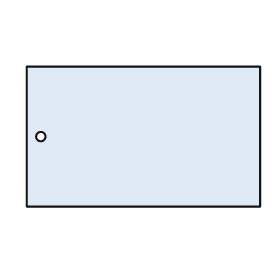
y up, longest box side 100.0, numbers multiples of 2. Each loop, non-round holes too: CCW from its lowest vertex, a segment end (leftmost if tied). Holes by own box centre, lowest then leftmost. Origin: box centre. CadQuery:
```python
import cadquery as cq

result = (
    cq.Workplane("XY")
    .moveTo(-50.0, -30.0)
    .lineTo(50.0, -30.0)
    .lineTo(50.0, 30.0)
    .lineTo(-50.0, 30.0)
    .close()
    .moveTo(-44.0, 0.0)
    .circle(2.0)
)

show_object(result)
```